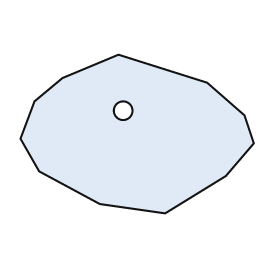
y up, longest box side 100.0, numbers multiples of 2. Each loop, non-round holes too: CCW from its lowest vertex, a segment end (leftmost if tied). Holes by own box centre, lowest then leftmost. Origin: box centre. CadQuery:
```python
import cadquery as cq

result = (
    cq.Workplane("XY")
    .moveTo(12.0, -34.0)
    .lineTo(38.0, -18.0)
    .lineTo(50.0, -4.0)
    .lineTo(46.0, 8.0)
    .lineTo(30.0, 22.0)
    .lineTo(-8.0, 34.0)
    .lineTo(-32.0, 24.0)
    .lineTo(-44.0, 14.0)
    .lineTo(-50.0, -2.0)
    .lineTo(-42.0, -16.0)
    .lineTo(-16.0, -30.0)
    .close()
    .moveTo(-6.0, 10.0)
    .circle(4.0)
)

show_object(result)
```